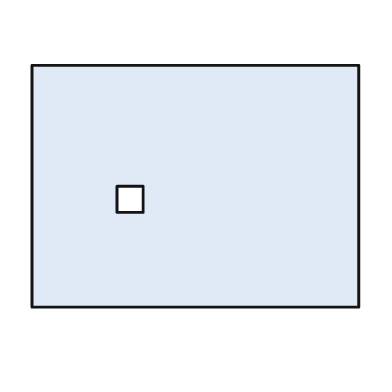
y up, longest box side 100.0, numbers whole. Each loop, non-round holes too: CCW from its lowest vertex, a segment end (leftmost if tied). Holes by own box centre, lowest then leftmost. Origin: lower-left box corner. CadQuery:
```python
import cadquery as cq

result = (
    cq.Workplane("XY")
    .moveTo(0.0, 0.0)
    .lineTo(100.0, 0.0)
    .lineTo(100.0, 74.0)
    .lineTo(0.0, 74.0)
    .close()
    .moveTo(26.0, 29.0)
    .lineTo(34.0, 29.0)
    .lineTo(34.0, 37.0)
    .lineTo(26.0, 37.0)
    .close()
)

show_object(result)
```